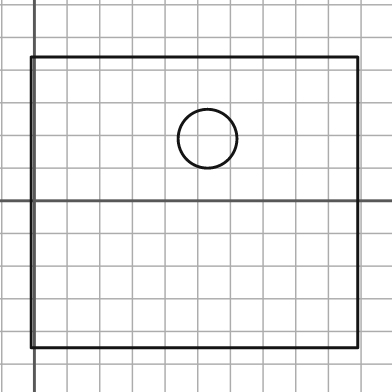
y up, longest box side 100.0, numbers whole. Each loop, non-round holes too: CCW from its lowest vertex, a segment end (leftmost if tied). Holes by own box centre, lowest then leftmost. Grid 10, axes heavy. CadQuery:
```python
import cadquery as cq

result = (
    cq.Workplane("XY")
    .moveTo(-1.0, -45.0)
    .lineTo(99.0, -45.0)
    .lineTo(99.0, 44.0)
    .lineTo(-1.0, 44.0)
    .close()
    .moveTo(53.0, 19.0)
    .circle(9.0)
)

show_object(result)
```